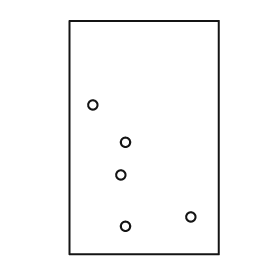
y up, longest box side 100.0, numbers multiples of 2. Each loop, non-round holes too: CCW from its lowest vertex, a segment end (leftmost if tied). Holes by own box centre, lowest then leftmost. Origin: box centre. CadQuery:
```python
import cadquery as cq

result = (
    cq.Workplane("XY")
    .moveTo(-32.0, -50.0)
    .lineTo(32.0, -50.0)
    .lineTo(32.0, 50.0)
    .lineTo(-32.0, 50.0)
    .close()
    .moveTo(-8.0, -38.0)
    .circle(2.0)
    .moveTo(20.0, -34.0)
    .circle(2.0)
    .moveTo(-10.0, -16.0)
    .circle(2.0)
    .moveTo(-8.0, -2.0)
    .circle(2.0)
    .moveTo(-22.0, 14.0)
    .circle(2.0)
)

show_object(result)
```